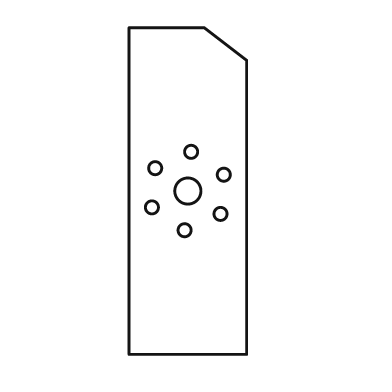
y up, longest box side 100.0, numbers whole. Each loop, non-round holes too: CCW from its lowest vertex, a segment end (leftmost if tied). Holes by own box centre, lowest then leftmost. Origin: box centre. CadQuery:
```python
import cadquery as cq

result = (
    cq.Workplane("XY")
    .moveTo(-18.0, -50.0)
    .lineTo(18.0, -50.0)
    .lineTo(18.0, 40.0)
    .lineTo(5.0, 50.0)
    .lineTo(-18.0, 50.0)
    .close()
    .moveTo(-1.0, -12.0)
    .circle(2.0)
    .moveTo(10.0, -7.0)
    .circle(2.0)
    .moveTo(-11.0, -5.0)
    .circle(2.0)
    .moveTo(0.0, 0.0)
    .circle(4.0)
    .moveTo(11.0, 5.0)
    .circle(2.0)
    .moveTo(-10.0, 7.0)
    .circle(2.0)
    .moveTo(1.0, 12.0)
    .circle(2.0)
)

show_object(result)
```